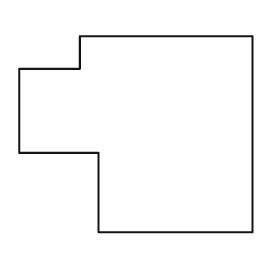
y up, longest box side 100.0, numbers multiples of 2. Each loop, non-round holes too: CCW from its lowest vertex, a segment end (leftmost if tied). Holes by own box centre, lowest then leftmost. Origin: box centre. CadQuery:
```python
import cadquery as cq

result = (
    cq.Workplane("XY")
    .moveTo(-16.0, -42.0)
    .lineTo(50.0, -42.0)
    .lineTo(50.0, 42.0)
    .lineTo(-24.0, 42.0)
    .lineTo(-24.0, 28.0)
    .lineTo(-50.0, 28.0)
    .lineTo(-50.0, -8.0)
    .lineTo(-16.0, -8.0)
    .close()
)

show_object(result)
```